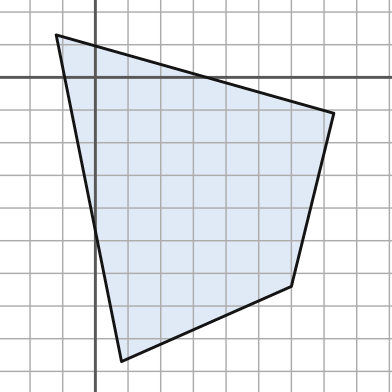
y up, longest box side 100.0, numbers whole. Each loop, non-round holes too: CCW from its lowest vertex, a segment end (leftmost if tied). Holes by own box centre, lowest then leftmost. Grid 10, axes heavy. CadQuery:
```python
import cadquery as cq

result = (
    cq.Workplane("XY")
    .moveTo(8.0, -87.0)
    .lineTo(60.0, -64.0)
    .lineTo(73.0, -11.0)
    .lineTo(-12.0, 13.0)
    .close()
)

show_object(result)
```